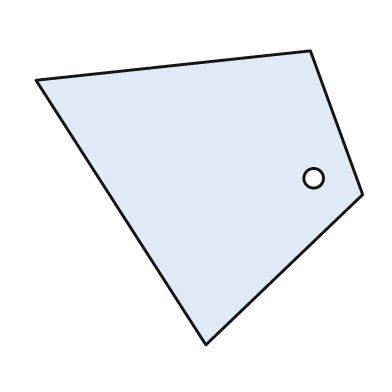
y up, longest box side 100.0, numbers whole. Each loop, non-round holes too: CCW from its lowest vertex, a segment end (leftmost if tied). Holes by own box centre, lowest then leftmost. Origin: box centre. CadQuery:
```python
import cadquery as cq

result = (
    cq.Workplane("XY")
    .moveTo(2.0, -45.0)
    .lineTo(50.0, 1.0)
    .lineTo(34.0, 45.0)
    .lineTo(-50.0, 36.0)
    .close()
    .moveTo(35.0, 6.0)
    .circle(3.0)
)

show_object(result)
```